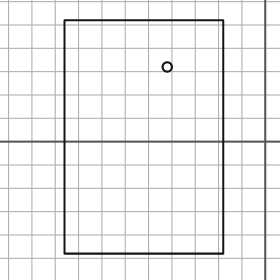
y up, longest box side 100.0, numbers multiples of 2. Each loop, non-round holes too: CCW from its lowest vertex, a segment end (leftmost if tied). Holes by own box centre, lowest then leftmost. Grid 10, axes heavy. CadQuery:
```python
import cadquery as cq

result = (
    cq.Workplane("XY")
    .moveTo(-86.0, -48.0)
    .lineTo(-18.0, -48.0)
    .lineTo(-18.0, 52.0)
    .lineTo(-86.0, 52.0)
    .close()
    .moveTo(-42.0, 32.0)
    .circle(2.0)
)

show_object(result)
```